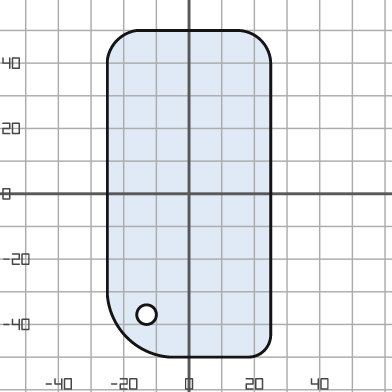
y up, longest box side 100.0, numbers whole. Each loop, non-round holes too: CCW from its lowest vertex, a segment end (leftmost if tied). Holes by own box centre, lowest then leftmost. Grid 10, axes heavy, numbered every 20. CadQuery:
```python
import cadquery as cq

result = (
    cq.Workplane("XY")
    .moveTo(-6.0, -50.0)
    .lineTo(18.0, -50.0)
    .threePointArc((23.0, -48.0), (25.0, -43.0))
    .lineTo(25.0, 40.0)
    .threePointArc((22.0, 47.0), (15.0, 50.0))
    .lineTo(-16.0, 50.0)
    .threePointArc((-22.0, 47.0), (-25.0, 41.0))
    .lineTo(-25.0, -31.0)
    .threePointArc((-19.0, -44.0), (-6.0, -50.0))
    .close()
    .moveTo(-13.0, -37.0)
    .circle(3.0)
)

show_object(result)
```